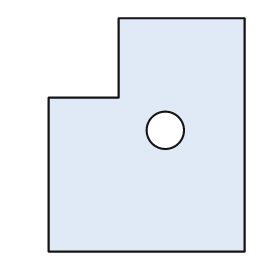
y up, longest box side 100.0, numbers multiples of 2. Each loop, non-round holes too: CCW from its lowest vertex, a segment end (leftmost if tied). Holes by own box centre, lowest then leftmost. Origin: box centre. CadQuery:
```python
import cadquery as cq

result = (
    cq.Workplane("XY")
    .moveTo(-42.0, -50.0)
    .lineTo(42.0, -50.0)
    .lineTo(42.0, 50.0)
    .lineTo(-12.0, 50.0)
    .lineTo(-12.0, 16.0)
    .lineTo(-42.0, 16.0)
    .close()
    .moveTo(8.0, 2.0)
    .circle(8.0)
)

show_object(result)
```